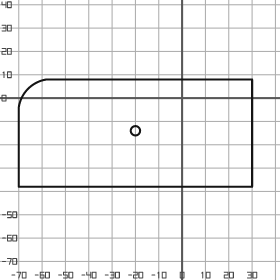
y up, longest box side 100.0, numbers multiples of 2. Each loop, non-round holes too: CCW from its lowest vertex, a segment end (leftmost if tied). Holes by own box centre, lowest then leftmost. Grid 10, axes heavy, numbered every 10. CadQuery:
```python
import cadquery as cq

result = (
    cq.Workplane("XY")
    .moveTo(-70.0, -38.0)
    .lineTo(30.0, -38.0)
    .lineTo(30.0, 8.0)
    .lineTo(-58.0, 8.0)
    .threePointArc((-66.0, 4.0), (-70.0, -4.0))
    .close()
    .moveTo(-20.0, -14.0)
    .circle(2.0)
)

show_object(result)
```